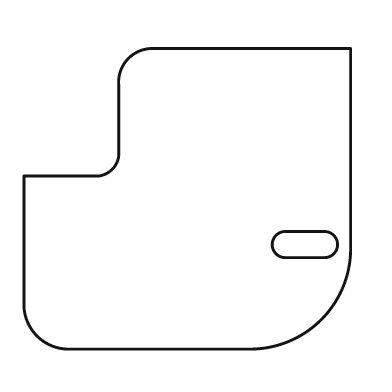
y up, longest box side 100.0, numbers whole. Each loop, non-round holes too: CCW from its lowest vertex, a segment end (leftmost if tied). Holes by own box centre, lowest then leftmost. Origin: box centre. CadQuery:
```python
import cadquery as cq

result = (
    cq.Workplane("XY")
    .moveTo(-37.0, -46.0)
    .lineTo(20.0, -46.0)
    .threePointArc((41.0, -37.0), (50.0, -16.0))
    .lineTo(50.0, 46.0)
    .lineTo(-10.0, 46.0)
    .threePointArc((-18.0, 43.0), (-21.0, 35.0))
    .lineTo(-21.0, 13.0)
    .threePointArc((-23.0, 9.0), (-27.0, 7.0))
    .lineTo(-50.0, 7.0)
    .lineTo(-50.0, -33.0)
    .threePointArc((-46.0, -42.0), (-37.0, -46.0))
    .close()
    .moveTo(30.0, -18.0)
    .lineTo(42.0, -18.0)
    .threePointArc((46.0, -14.0), (42.0, -10.0))
    .lineTo(30.0, -10.0)
    .threePointArc((26.0, -14.0), (30.0, -18.0))
    .close()
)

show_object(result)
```